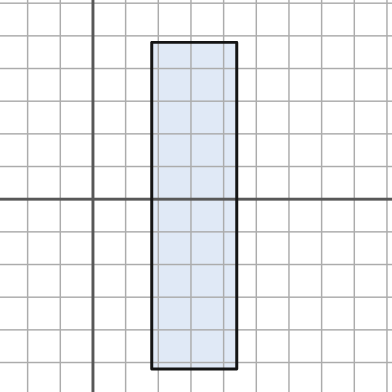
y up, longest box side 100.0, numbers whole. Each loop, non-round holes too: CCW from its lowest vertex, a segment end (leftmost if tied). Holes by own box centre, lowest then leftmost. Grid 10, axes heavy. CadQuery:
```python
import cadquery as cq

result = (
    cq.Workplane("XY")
    .moveTo(18.0, -52.0)
    .lineTo(44.0, -52.0)
    .lineTo(44.0, 48.0)
    .lineTo(18.0, 48.0)
    .close()
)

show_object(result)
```